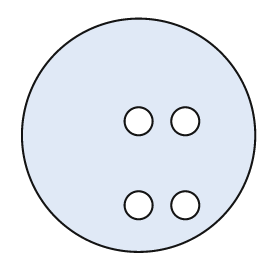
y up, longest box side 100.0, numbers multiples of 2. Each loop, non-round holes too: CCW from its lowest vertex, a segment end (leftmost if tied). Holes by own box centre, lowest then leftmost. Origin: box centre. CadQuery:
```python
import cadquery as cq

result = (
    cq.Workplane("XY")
    .moveTo(0.0, 0.0)
    .circle(50.0)
    .moveTo(0.0, -30.0)
    .circle(6.0)
    .moveTo(20.0, -30.0)
    .circle(6.0)
    .moveTo(0.0, 6.0)
    .circle(6.0)
    .moveTo(20.0, 6.0)
    .circle(6.0)
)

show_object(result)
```